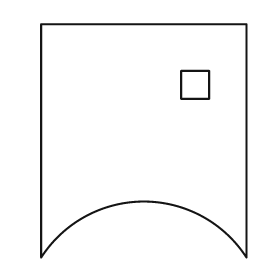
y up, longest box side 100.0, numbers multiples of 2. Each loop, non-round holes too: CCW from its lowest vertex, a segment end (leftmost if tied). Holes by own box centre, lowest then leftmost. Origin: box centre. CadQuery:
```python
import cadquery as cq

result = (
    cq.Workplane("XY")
    .moveTo(-44.0, -50.0)
    .threePointArc((0.0, -26.0), (44.0, -50.0))
    .lineTo(44.0, 50.0)
    .lineTo(-44.0, 50.0)
    .close()
    .moveTo(16.0, 18.0)
    .lineTo(28.0, 18.0)
    .lineTo(28.0, 30.0)
    .lineTo(16.0, 30.0)
    .close()
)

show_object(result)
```